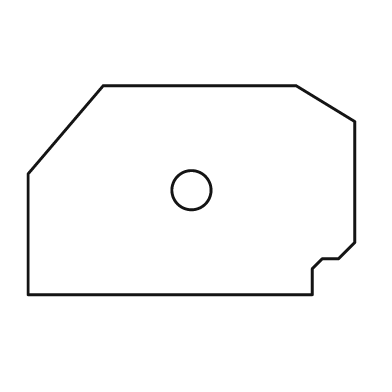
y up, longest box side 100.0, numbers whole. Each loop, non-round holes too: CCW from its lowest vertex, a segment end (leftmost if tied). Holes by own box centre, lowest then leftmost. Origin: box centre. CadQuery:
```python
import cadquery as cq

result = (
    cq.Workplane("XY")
    .moveTo(-50.0, -32.0)
    .lineTo(37.0, -32.0)
    .lineTo(37.0, -24.0)
    .lineTo(40.0, -21.0)
    .lineTo(45.0, -21.0)
    .lineTo(50.0, -16.0)
    .lineTo(50.0, 21.0)
    .lineTo(32.0, 32.0)
    .lineTo(-27.0, 32.0)
    .lineTo(-50.0, 5.0)
    .close()
    .moveTo(0.0, 0.0)
    .circle(6.0)
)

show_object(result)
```